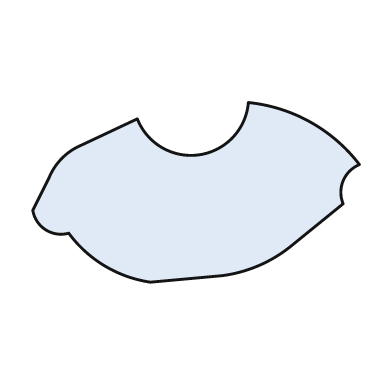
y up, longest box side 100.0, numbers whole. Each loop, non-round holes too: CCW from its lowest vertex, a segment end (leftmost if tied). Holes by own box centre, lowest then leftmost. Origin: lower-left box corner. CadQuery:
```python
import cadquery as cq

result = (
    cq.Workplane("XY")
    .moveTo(36.0, 0.0)
    .lineTo(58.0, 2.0)
    .threePointArc((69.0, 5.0), (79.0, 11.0))
    .lineTo(95.0, 24.0)
    .threePointArc((95.0, 31.0), (100.0, 36.0))
    .threePointArc((85.0, 49.0), (66.0, 55.0))
    .threePointArc((51.0, 39.0), (32.0, 50.0))
    .lineTo(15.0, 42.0)
    .threePointArc((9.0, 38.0), (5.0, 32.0))
    .lineTo(0.0, 22.0)
    .threePointArc((4.0, 16.0), (11.0, 15.0))
    .threePointArc((22.0, 5.0), (36.0, 0.0))
    .close()
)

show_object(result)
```